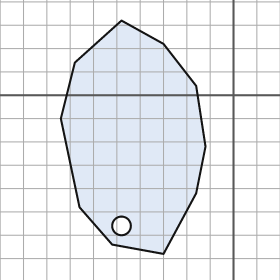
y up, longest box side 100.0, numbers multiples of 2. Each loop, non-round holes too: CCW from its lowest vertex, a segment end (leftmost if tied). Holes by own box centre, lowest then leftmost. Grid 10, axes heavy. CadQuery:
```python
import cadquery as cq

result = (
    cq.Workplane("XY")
    .moveTo(-30.0, -68.0)
    .lineTo(-16.0, -42.0)
    .lineTo(-12.0, -22.0)
    .lineTo(-16.0, 4.0)
    .lineTo(-30.0, 22.0)
    .lineTo(-48.0, 32.0)
    .lineTo(-68.0, 14.0)
    .lineTo(-74.0, -10.0)
    .lineTo(-66.0, -48.0)
    .lineTo(-52.0, -64.0)
    .close()
    .moveTo(-48.0, -56.0)
    .circle(4.0)
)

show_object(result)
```